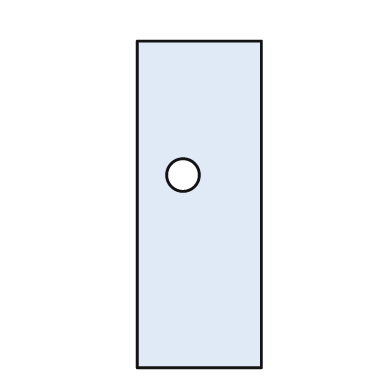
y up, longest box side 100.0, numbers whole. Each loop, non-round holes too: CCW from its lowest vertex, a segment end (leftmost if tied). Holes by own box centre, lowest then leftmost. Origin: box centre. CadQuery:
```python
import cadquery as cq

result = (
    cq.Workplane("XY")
    .moveTo(-19.0, -50.0)
    .lineTo(19.0, -50.0)
    .lineTo(19.0, 50.0)
    .lineTo(-19.0, 50.0)
    .close()
    .moveTo(-5.0, 9.0)
    .circle(5.0)
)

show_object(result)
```